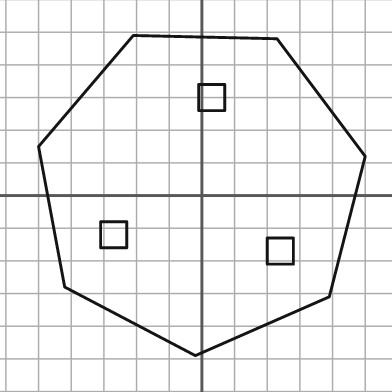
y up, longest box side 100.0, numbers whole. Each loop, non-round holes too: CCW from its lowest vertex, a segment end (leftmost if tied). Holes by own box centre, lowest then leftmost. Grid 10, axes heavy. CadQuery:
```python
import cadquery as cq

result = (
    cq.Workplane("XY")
    .moveTo(-2.0, -49.0)
    .lineTo(39.0, -31.0)
    .lineTo(50.0, 12.0)
    .lineTo(23.0, 48.0)
    .lineTo(-21.0, 49.0)
    .lineTo(-50.0, 15.0)
    .lineTo(-42.0, -28.0)
    .close()
    .moveTo(20.0, -21.0)
    .lineTo(28.0, -21.0)
    .lineTo(28.0, -13.0)
    .lineTo(20.0, -13.0)
    .close()
    .moveTo(-31.0, -16.0)
    .lineTo(-23.0, -16.0)
    .lineTo(-23.0, -8.0)
    .lineTo(-31.0, -8.0)
    .close()
    .moveTo(-1.0, 26.0)
    .lineTo(7.0, 26.0)
    .lineTo(7.0, 34.0)
    .lineTo(-1.0, 34.0)
    .close()
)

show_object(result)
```